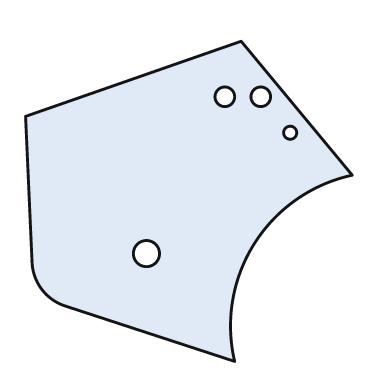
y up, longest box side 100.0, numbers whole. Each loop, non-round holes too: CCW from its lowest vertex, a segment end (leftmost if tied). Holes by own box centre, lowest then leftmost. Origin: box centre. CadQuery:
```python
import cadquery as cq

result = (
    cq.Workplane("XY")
    .moveTo(14.0, -49.0)
    .threePointArc((20.0, -13.0), (50.0, 8.0))
    .lineTo(16.0, 49.0)
    .lineTo(-50.0, 26.0)
    .lineTo(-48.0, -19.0)
    .threePointArc((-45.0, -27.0), (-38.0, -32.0))
    .close()
    .moveTo(-13.0, -16.0)
    .circle(4.0)
    .moveTo(31.0, 21.0)
    .circle(2.0)
    .moveTo(11.0, 32.0)
    .circle(3.0)
    .moveTo(22.0, 32.0)
    .circle(3.0)
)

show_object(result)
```